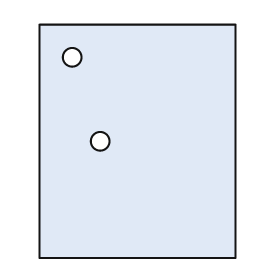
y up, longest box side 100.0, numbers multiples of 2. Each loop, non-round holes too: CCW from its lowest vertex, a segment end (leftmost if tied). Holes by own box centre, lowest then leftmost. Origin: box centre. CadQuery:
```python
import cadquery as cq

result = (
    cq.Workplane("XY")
    .moveTo(-42.0, -50.0)
    .lineTo(42.0, -50.0)
    .lineTo(42.0, 50.0)
    .lineTo(-42.0, 50.0)
    .close()
    .moveTo(-16.0, 0.0)
    .circle(4.0)
    .moveTo(-28.0, 36.0)
    .circle(4.0)
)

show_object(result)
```